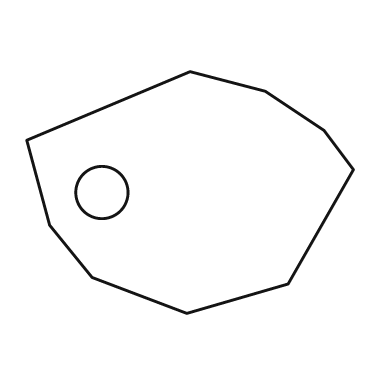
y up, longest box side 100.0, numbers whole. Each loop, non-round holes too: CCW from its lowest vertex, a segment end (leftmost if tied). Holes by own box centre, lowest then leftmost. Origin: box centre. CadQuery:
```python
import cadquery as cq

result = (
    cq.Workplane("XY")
    .moveTo(-1.0, -37.0)
    .lineTo(30.0, -28.0)
    .lineTo(50.0, 7.0)
    .lineTo(41.0, 19.0)
    .lineTo(23.0, 31.0)
    .lineTo(0.0, 37.0)
    .lineTo(-50.0, 16.0)
    .lineTo(-43.0, -10.0)
    .lineTo(-30.0, -26.0)
    .close()
    .moveTo(-27.0, 0.0)
    .circle(8.0)
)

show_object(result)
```